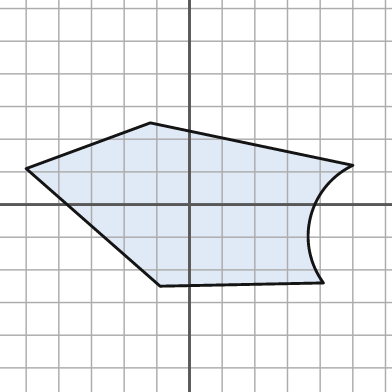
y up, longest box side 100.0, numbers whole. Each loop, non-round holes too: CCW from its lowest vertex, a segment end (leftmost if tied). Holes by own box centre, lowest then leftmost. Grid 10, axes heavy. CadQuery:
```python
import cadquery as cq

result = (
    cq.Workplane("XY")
    .moveTo(-9.0, -25.0)
    .lineTo(41.0, -24.0)
    .threePointArc((37.0, -4.0), (50.0, 12.0))
    .lineTo(-12.0, 25.0)
    .lineTo(-50.0, 11.0)
    .close()
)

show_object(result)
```